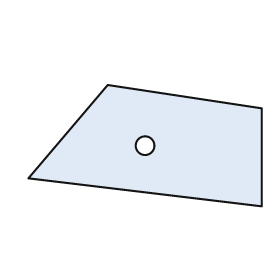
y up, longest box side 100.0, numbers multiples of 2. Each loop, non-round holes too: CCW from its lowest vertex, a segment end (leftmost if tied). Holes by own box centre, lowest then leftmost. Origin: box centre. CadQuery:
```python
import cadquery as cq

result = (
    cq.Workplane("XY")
    .moveTo(50.0, -26.0)
    .lineTo(50.0, 16.0)
    .lineTo(-16.0, 26.0)
    .lineTo(-50.0, -14.0)
    .close()
    .moveTo(0.0, 0.0)
    .circle(4.0)
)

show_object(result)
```